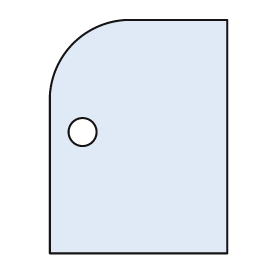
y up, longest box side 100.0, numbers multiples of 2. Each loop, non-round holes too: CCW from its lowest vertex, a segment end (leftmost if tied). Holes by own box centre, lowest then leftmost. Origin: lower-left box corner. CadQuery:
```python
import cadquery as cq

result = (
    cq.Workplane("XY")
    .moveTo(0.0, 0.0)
    .lineTo(76.0, 0.0)
    .lineTo(76.0, 100.0)
    .lineTo(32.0, 100.0)
    .threePointArc((10.0, 90.0), (0.0, 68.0))
    .close()
    .moveTo(14.0, 52.0)
    .circle(6.0)
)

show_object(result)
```